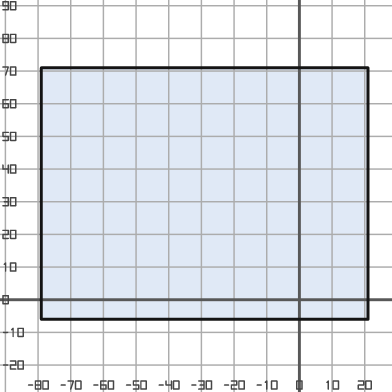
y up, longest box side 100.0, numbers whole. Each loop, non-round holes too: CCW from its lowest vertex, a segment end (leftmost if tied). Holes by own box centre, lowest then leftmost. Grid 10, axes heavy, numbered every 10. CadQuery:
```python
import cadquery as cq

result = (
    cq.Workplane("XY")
    .moveTo(-79.0, -6.0)
    .lineTo(21.0, -6.0)
    .lineTo(21.0, 71.0)
    .lineTo(-79.0, 71.0)
    .close()
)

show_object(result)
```